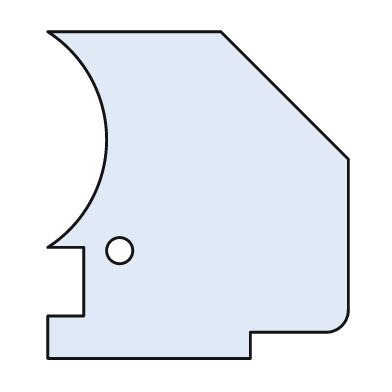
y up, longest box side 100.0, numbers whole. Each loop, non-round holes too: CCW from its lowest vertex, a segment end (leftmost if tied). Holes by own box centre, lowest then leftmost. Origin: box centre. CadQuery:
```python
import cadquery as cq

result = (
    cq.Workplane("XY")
    .moveTo(-46.0, -50.0)
    .lineTo(16.0, -50.0)
    .lineTo(16.0, -42.0)
    .lineTo(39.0, -42.0)
    .threePointArc((44.0, -40.0), (46.0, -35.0))
    .lineTo(46.0, 11.0)
    .lineTo(7.0, 50.0)
    .lineTo(-46.0, 50.0)
    .threePointArc((-28.0, 17.0), (-46.0, -16.0))
    .lineTo(-35.0, -16.0)
    .lineTo(-35.0, -37.0)
    .lineTo(-46.0, -37.0)
    .close()
    .moveTo(-24.0, -17.0)
    .circle(4.0)
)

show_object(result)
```